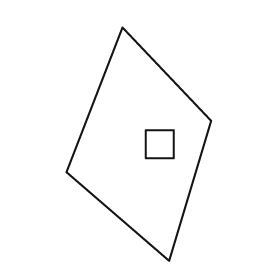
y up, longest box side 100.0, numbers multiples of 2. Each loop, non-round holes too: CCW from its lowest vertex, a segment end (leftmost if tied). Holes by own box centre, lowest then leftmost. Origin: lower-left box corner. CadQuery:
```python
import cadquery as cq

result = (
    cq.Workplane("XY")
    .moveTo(44.0, 0.0)
    .lineTo(62.0, 60.0)
    .lineTo(24.0, 100.0)
    .lineTo(0.0, 38.0)
    .close()
    .moveTo(34.0, 44.0)
    .lineTo(46.0, 44.0)
    .lineTo(46.0, 56.0)
    .lineTo(34.0, 56.0)
    .close()
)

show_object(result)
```